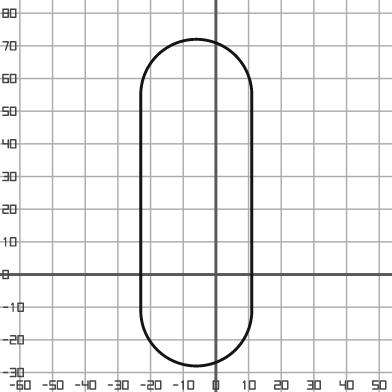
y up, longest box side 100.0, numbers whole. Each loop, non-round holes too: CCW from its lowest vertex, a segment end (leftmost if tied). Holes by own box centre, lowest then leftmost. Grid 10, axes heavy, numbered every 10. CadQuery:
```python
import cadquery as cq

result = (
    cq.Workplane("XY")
    .moveTo(-23.0, -11.0)
    .threePointArc((-6.0, -28.0), (11.0, -11.0))
    .lineTo(11.0, 55.0)
    .threePointArc((-6.0, 72.0), (-23.0, 55.0))
    .close()
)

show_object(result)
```